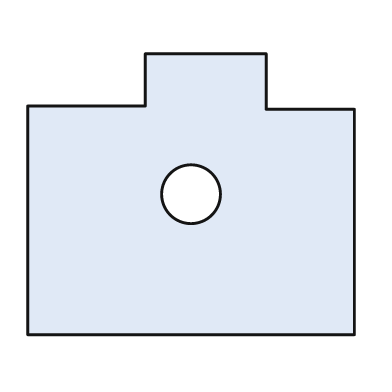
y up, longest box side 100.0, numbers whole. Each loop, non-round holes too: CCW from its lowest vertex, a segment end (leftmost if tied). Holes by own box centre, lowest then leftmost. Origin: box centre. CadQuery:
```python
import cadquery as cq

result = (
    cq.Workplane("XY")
    .moveTo(-50.0, -43.0)
    .lineTo(50.0, -43.0)
    .lineTo(50.0, 26.0)
    .lineTo(23.0, 26.0)
    .lineTo(23.0, 43.0)
    .lineTo(-14.0, 43.0)
    .lineTo(-14.0, 27.0)
    .lineTo(-50.0, 27.0)
    .close()
    .moveTo(0.0, 0.0)
    .circle(9.0)
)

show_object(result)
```